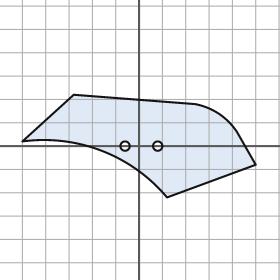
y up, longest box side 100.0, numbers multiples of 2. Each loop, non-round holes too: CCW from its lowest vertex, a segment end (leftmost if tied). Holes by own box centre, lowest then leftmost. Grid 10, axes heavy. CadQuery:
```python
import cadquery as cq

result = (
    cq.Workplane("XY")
    .moveTo(12.0, -22.0)
    .lineTo(50.0, -8.0)
    .lineTo(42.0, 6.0)
    .threePointArc((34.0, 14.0), (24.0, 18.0))
    .lineTo(-28.0, 22.0)
    .lineTo(-50.0, 2.0)
    .threePointArc((-16.0, -2.0), (12.0, -22.0))
    .close()
    .moveTo(-6.0, 0.0)
    .circle(2.0)
    .moveTo(8.0, 0.0)
    .circle(2.0)
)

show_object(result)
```